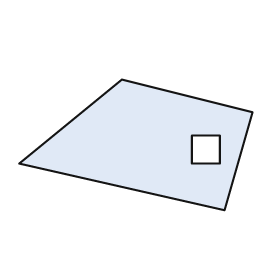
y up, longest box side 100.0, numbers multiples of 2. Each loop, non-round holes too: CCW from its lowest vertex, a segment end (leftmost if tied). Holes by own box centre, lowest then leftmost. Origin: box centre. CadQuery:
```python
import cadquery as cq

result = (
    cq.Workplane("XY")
    .moveTo(38.0, -28.0)
    .lineTo(50.0, 14.0)
    .lineTo(-6.0, 28.0)
    .lineTo(-50.0, -8.0)
    .close()
    .moveTo(24.0, -8.0)
    .lineTo(36.0, -8.0)
    .lineTo(36.0, 4.0)
    .lineTo(24.0, 4.0)
    .close()
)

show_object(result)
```